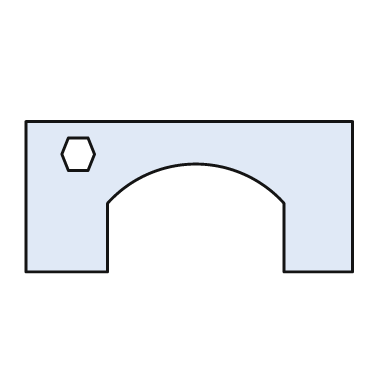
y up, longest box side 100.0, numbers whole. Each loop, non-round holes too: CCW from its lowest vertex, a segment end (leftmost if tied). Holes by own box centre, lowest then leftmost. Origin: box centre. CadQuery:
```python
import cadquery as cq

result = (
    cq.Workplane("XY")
    .moveTo(-50.0, -23.0)
    .lineTo(-25.0, -23.0)
    .lineTo(-25.0, -2.0)
    .threePointArc((2.0, 10.0), (29.0, -2.0))
    .lineTo(29.0, -23.0)
    .lineTo(50.0, -23.0)
    .lineTo(50.0, 23.0)
    .lineTo(-50.0, 23.0)
    .close()
    .moveTo(-37.0, 8.0)
    .lineTo(-31.0, 8.0)
    .lineTo(-29.0, 13.0)
    .lineTo(-31.0, 18.0)
    .lineTo(-37.0, 18.0)
    .lineTo(-39.0, 13.0)
    .close()
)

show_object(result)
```